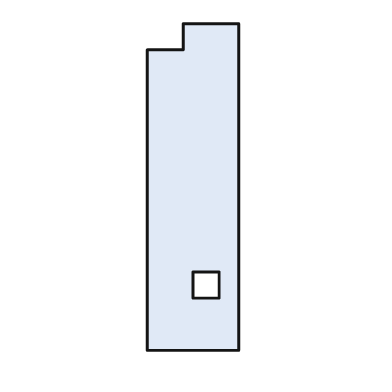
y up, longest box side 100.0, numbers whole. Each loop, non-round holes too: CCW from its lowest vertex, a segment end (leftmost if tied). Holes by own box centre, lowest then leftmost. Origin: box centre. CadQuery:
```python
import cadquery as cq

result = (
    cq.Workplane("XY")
    .moveTo(-14.0, -50.0)
    .lineTo(14.0, -50.0)
    .lineTo(14.0, 50.0)
    .lineTo(-3.0, 50.0)
    .lineTo(-3.0, 42.0)
    .lineTo(-14.0, 42.0)
    .close()
    .moveTo(0.0, -34.0)
    .lineTo(8.0, -34.0)
    .lineTo(8.0, -26.0)
    .lineTo(0.0, -26.0)
    .close()
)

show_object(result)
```